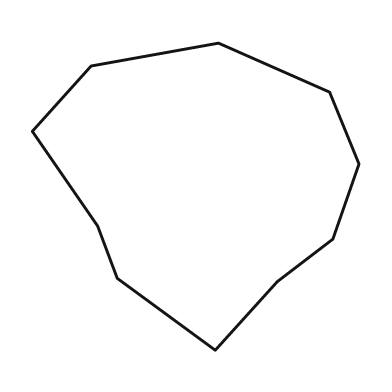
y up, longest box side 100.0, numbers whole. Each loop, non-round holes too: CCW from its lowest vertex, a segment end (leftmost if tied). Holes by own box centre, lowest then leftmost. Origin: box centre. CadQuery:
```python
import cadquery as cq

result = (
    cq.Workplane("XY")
    .moveTo(6.0, -47.0)
    .lineTo(25.0, -26.0)
    .lineTo(42.0, -13.0)
    .lineTo(50.0, 10.0)
    .lineTo(41.0, 32.0)
    .lineTo(7.0, 47.0)
    .lineTo(-32.0, 40.0)
    .lineTo(-50.0, 20.0)
    .lineTo(-30.0, -9.0)
    .lineTo(-24.0, -25.0)
    .close()
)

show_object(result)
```